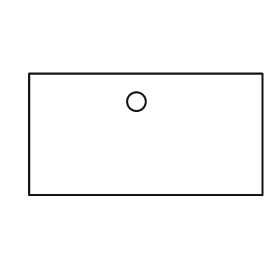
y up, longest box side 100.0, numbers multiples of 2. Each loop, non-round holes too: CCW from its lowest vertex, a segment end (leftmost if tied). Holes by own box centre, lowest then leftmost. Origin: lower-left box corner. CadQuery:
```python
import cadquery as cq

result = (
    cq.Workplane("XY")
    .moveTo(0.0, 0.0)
    .lineTo(100.0, 0.0)
    .lineTo(100.0, 52.0)
    .lineTo(0.0, 52.0)
    .close()
    .moveTo(46.0, 40.0)
    .circle(4.0)
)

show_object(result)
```